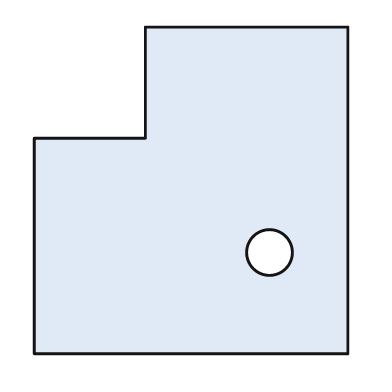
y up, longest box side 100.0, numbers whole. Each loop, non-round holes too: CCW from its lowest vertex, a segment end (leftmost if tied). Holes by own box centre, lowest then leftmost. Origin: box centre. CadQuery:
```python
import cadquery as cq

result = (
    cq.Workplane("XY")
    .moveTo(-48.0, -50.0)
    .lineTo(48.0, -50.0)
    .lineTo(48.0, 50.0)
    .lineTo(-14.0, 50.0)
    .lineTo(-14.0, 16.0)
    .lineTo(-48.0, 16.0)
    .close()
    .moveTo(24.0, -19.0)
    .circle(7.0)
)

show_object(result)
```